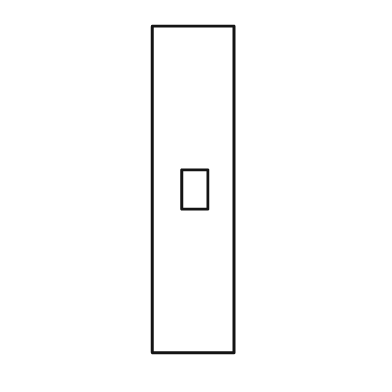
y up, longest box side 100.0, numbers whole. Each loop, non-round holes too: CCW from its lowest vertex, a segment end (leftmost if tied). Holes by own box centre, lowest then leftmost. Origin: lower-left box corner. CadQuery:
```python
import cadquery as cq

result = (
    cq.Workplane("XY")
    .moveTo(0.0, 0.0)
    .lineTo(25.0, 0.0)
    .lineTo(25.0, 100.0)
    .lineTo(0.0, 100.0)
    .close()
    .moveTo(9.0, 44.0)
    .lineTo(17.0, 44.0)
    .lineTo(17.0, 56.0)
    .lineTo(9.0, 56.0)
    .close()
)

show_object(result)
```